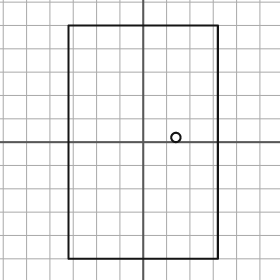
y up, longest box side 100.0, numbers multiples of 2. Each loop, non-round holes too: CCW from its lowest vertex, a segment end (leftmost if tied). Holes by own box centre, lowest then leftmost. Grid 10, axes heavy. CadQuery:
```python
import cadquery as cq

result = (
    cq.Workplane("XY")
    .moveTo(-32.0, -50.0)
    .lineTo(32.0, -50.0)
    .lineTo(32.0, 50.0)
    .lineTo(-32.0, 50.0)
    .close()
    .moveTo(14.0, 2.0)
    .circle(2.0)
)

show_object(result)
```